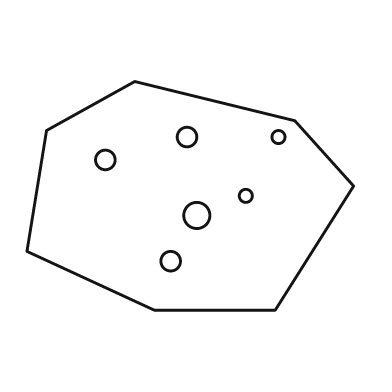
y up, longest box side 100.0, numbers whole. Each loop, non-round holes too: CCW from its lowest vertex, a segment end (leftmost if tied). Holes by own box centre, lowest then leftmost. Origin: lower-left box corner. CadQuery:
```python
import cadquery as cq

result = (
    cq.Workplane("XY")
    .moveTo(39.0, 0.0)
    .lineTo(76.0, 0.0)
    .lineTo(100.0, 38.0)
    .lineTo(82.0, 58.0)
    .lineTo(33.0, 70.0)
    .lineTo(6.0, 55.0)
    .lineTo(0.0, 18.0)
    .close()
    .moveTo(44.0, 15.0)
    .circle(3.0)
    .moveTo(52.0, 29.0)
    .circle(4.0)
    .moveTo(67.0, 35.0)
    .circle(2.0)
    .moveTo(24.0, 46.0)
    .circle(3.0)
    .moveTo(49.0, 53.0)
    .circle(3.0)
    .moveTo(77.0, 53.0)
    .circle(2.0)
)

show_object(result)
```